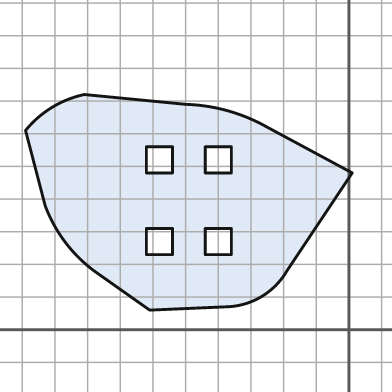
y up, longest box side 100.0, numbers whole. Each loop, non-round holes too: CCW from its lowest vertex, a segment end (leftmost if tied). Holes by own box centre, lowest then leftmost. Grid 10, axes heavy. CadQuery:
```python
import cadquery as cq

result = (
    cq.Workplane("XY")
    .moveTo(-61.0, 6.0)
    .lineTo(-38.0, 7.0)
    .threePointArc((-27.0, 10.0), (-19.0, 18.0))
    .lineTo(1.0, 48.0)
    .lineTo(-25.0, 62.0)
    .threePointArc((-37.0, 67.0), (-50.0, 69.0))
    .lineTo(-81.0, 72.0)
    .threePointArc((-91.0, 68.0), (-99.0, 61.0))
    .lineTo(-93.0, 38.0)
    .threePointArc((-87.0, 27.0), (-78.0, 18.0))
    .close()
    .moveTo(-62.0, 23.0)
    .lineTo(-54.0, 23.0)
    .lineTo(-54.0, 31.0)
    .lineTo(-62.0, 31.0)
    .close()
    .moveTo(-44.0, 23.0)
    .lineTo(-36.0, 23.0)
    .lineTo(-36.0, 31.0)
    .lineTo(-44.0, 31.0)
    .close()
    .moveTo(-62.0, 48.0)
    .lineTo(-54.0, 48.0)
    .lineTo(-54.0, 56.0)
    .lineTo(-62.0, 56.0)
    .close()
    .moveTo(-44.0, 48.0)
    .lineTo(-36.0, 48.0)
    .lineTo(-36.0, 56.0)
    .lineTo(-44.0, 56.0)
    .close()
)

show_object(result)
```